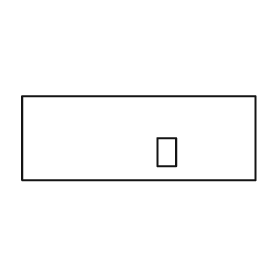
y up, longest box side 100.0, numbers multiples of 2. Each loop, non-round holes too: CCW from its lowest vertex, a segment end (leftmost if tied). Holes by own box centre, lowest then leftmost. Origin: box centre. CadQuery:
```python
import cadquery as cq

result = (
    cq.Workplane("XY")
    .moveTo(-50.0, -18.0)
    .lineTo(50.0, -18.0)
    .lineTo(50.0, 18.0)
    .lineTo(-50.0, 18.0)
    .close()
    .moveTo(8.0, -12.0)
    .lineTo(16.0, -12.0)
    .lineTo(16.0, 0.0)
    .lineTo(8.0, 0.0)
    .close()
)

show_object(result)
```